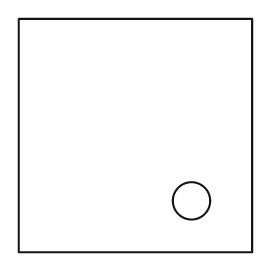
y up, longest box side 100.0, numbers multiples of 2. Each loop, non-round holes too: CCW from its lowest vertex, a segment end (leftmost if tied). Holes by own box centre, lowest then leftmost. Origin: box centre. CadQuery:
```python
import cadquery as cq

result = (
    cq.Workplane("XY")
    .moveTo(-50.0, -50.0)
    .lineTo(50.0, -50.0)
    .lineTo(50.0, 50.0)
    .lineTo(-50.0, 50.0)
    .close()
    .moveTo(24.0, -28.0)
    .circle(8.0)
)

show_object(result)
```